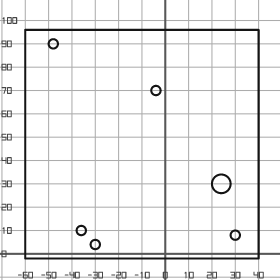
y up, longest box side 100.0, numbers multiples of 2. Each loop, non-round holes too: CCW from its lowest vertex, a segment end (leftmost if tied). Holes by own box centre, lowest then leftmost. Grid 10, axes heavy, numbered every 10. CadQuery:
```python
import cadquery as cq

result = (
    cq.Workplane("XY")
    .moveTo(-60.0, -2.0)
    .lineTo(40.0, -2.0)
    .lineTo(40.0, 96.0)
    .lineTo(-60.0, 96.0)
    .close()
    .moveTo(-30.0, 4.0)
    .circle(2.0)
    .moveTo(30.0, 8.0)
    .circle(2.0)
    .moveTo(-36.0, 10.0)
    .circle(2.0)
    .moveTo(24.0, 30.0)
    .circle(4.0)
    .moveTo(-4.0, 70.0)
    .circle(2.0)
    .moveTo(-48.0, 90.0)
    .circle(2.0)
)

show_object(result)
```